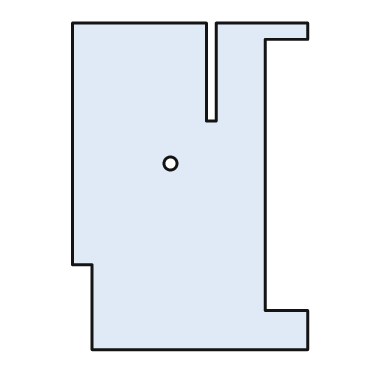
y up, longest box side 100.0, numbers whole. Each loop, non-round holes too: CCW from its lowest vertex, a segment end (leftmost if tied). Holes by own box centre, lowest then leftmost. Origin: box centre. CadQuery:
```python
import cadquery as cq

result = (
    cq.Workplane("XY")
    .moveTo(-30.0, -50.0)
    .lineTo(36.0, -50.0)
    .lineTo(36.0, -38.0)
    .lineTo(23.0, -38.0)
    .lineTo(23.0, 45.0)
    .lineTo(36.0, 45.0)
    .lineTo(36.0, 50.0)
    .lineTo(8.0, 50.0)
    .lineTo(8.0, 20.0)
    .lineTo(5.0, 20.0)
    .lineTo(5.0, 50.0)
    .lineTo(-36.0, 50.0)
    .lineTo(-36.0, -24.0)
    .lineTo(-30.0, -24.0)
    .close()
    .moveTo(-6.0, 7.0)
    .circle(2.0)
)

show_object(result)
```